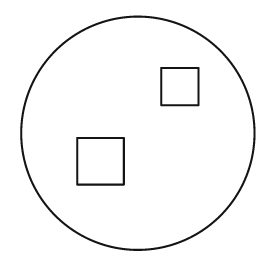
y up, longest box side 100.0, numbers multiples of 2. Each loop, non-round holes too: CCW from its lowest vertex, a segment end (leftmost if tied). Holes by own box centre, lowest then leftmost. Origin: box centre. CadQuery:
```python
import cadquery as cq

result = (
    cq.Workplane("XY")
    .moveTo(0.0, 0.0)
    .circle(50.0)
    .moveTo(-26.0, -22.0)
    .lineTo(-6.0, -22.0)
    .lineTo(-6.0, -2.0)
    .lineTo(-26.0, -2.0)
    .close()
    .moveTo(10.0, 12.0)
    .lineTo(26.0, 12.0)
    .lineTo(26.0, 28.0)
    .lineTo(10.0, 28.0)
    .close()
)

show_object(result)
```